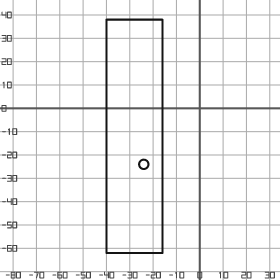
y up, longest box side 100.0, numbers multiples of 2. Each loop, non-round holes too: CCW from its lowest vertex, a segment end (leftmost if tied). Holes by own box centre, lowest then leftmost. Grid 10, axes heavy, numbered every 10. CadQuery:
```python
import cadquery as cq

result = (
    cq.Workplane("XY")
    .moveTo(-40.0, -62.0)
    .lineTo(-16.0, -62.0)
    .lineTo(-16.0, 38.0)
    .lineTo(-40.0, 38.0)
    .close()
    .moveTo(-24.0, -24.0)
    .circle(2.0)
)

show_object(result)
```